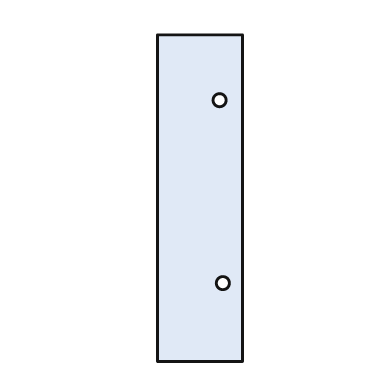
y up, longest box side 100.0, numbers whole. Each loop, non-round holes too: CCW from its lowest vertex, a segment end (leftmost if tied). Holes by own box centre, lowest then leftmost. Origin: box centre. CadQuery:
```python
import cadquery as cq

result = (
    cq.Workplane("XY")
    .moveTo(-13.0, -50.0)
    .lineTo(13.0, -50.0)
    .lineTo(13.0, 50.0)
    .lineTo(-13.0, 50.0)
    .close()
    .moveTo(7.0, -26.0)
    .circle(2.0)
    .moveTo(6.0, 30.0)
    .circle(2.0)
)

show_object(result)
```